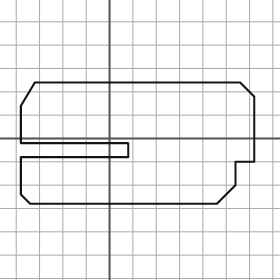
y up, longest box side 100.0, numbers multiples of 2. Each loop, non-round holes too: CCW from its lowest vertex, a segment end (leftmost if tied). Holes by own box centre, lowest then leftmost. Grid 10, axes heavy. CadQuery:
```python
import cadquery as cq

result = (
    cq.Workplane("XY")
    .moveTo(-34.0, -28.0)
    .lineTo(46.0, -28.0)
    .lineTo(54.0, -20.0)
    .lineTo(54.0, -10.0)
    .lineTo(62.0, -10.0)
    .lineTo(62.0, 18.0)
    .lineTo(56.0, 24.0)
    .lineTo(-32.0, 24.0)
    .lineTo(-38.0, 14.0)
    .lineTo(-38.0, -2.0)
    .lineTo(8.0, -2.0)
    .lineTo(8.0, -8.0)
    .lineTo(-38.0, -8.0)
    .lineTo(-38.0, -24.0)
    .close()
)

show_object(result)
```